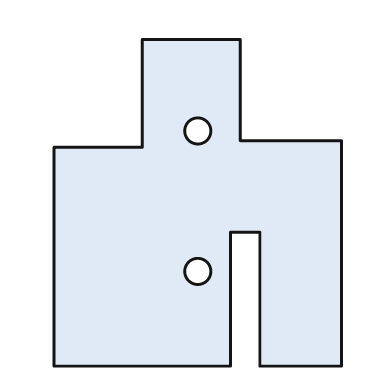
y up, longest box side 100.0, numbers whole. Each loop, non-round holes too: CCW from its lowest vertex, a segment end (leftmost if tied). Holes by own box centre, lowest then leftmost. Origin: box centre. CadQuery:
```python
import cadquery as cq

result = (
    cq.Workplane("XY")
    .moveTo(-44.0, -50.0)
    .lineTo(10.0, -50.0)
    .lineTo(10.0, -9.0)
    .lineTo(19.0, -9.0)
    .lineTo(19.0, -50.0)
    .lineTo(44.0, -50.0)
    .lineTo(44.0, 19.0)
    .lineTo(13.0, 19.0)
    .lineTo(13.0, 50.0)
    .lineTo(-17.0, 50.0)
    .lineTo(-17.0, 17.0)
    .lineTo(-44.0, 17.0)
    .close()
    .moveTo(0.0, -21.0)
    .circle(4.0)
    .moveTo(0.0, 22.0)
    .circle(4.0)
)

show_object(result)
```